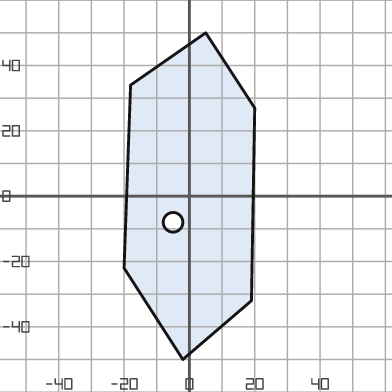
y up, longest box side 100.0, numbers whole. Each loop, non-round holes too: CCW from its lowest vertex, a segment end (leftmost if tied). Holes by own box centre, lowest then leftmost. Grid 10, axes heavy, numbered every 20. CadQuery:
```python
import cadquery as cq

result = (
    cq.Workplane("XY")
    .moveTo(-2.0, -50.0)
    .lineTo(19.0, -32.0)
    .lineTo(20.0, 27.0)
    .lineTo(5.0, 50.0)
    .lineTo(-18.0, 34.0)
    .lineTo(-20.0, -22.0)
    .close()
    .moveTo(-5.0, -8.0)
    .circle(3.0)
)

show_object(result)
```